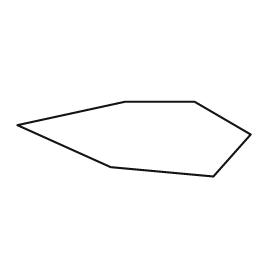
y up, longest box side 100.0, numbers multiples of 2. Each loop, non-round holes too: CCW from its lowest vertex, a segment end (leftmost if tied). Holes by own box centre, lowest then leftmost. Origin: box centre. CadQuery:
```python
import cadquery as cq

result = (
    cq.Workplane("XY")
    .moveTo(34.0, -16.0)
    .lineTo(50.0, 2.0)
    .lineTo(26.0, 16.0)
    .lineTo(-4.0, 16.0)
    .lineTo(-50.0, 6.0)
    .lineTo(-10.0, -12.0)
    .close()
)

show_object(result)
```